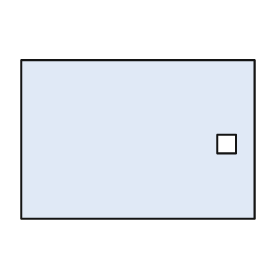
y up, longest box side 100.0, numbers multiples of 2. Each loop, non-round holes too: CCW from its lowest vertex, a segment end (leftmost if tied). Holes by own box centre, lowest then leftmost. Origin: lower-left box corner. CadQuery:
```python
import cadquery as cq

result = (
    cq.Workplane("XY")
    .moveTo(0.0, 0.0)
    .lineTo(100.0, 0.0)
    .lineTo(100.0, 68.0)
    .lineTo(0.0, 68.0)
    .close()
    .moveTo(84.0, 28.0)
    .lineTo(92.0, 28.0)
    .lineTo(92.0, 36.0)
    .lineTo(84.0, 36.0)
    .close()
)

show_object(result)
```